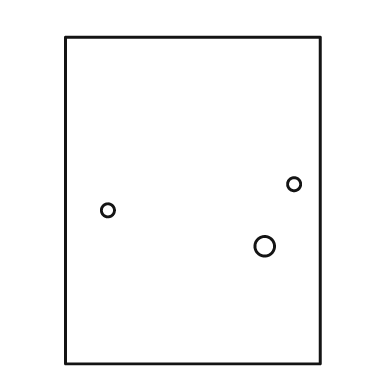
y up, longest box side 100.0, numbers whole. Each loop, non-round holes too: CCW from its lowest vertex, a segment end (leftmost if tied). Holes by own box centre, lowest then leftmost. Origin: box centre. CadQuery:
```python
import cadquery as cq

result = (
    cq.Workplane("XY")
    .moveTo(-39.0, -50.0)
    .lineTo(39.0, -50.0)
    .lineTo(39.0, 50.0)
    .lineTo(-39.0, 50.0)
    .close()
    .moveTo(22.0, -14.0)
    .circle(3.0)
    .moveTo(-26.0, -3.0)
    .circle(2.0)
    .moveTo(31.0, 5.0)
    .circle(2.0)
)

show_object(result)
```